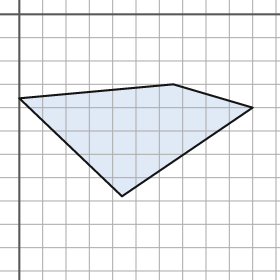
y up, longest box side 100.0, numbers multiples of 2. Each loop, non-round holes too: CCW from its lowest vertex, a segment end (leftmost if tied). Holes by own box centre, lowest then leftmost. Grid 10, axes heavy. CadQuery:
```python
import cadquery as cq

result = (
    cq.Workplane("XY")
    .moveTo(44.0, -78.0)
    .lineTo(100.0, -40.0)
    .lineTo(66.0, -30.0)
    .lineTo(0.0, -36.0)
    .close()
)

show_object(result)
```